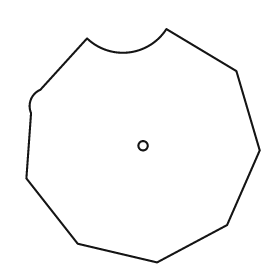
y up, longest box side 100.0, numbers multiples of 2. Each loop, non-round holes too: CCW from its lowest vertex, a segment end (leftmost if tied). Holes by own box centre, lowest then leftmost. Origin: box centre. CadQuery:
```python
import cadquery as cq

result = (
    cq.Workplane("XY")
    .moveTo(6.0, -50.0)
    .lineTo(36.0, -34.0)
    .lineTo(50.0, -2.0)
    .lineTo(40.0, 32.0)
    .lineTo(10.0, 50.0)
    .threePointArc((-6.0, 40.0), (-24.0, 46.0))
    .lineTo(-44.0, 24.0)
    .threePointArc((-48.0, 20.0), (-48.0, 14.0))
    .lineTo(-50.0, -14.0)
    .lineTo(-28.0, -42.0)
    .close()
    .moveTo(0.0, 0.0)
    .circle(2.0)
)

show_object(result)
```